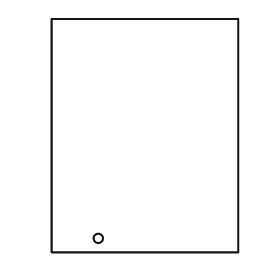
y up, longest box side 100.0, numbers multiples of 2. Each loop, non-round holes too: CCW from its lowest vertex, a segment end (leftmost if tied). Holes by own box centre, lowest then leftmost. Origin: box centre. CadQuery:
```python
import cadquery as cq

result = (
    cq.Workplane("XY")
    .moveTo(-40.0, -50.0)
    .lineTo(40.0, -50.0)
    .lineTo(40.0, 50.0)
    .lineTo(-40.0, 50.0)
    .close()
    .moveTo(-20.0, -44.0)
    .circle(2.0)
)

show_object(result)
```